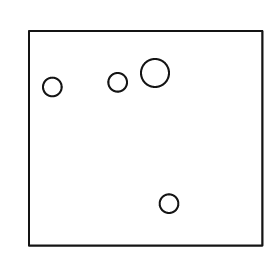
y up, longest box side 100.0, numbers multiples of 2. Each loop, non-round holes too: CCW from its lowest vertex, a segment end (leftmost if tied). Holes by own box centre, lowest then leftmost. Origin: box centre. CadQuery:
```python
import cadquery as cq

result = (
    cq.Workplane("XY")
    .moveTo(-50.0, -46.0)
    .lineTo(50.0, -46.0)
    .lineTo(50.0, 46.0)
    .lineTo(-50.0, 46.0)
    .close()
    .moveTo(10.0, -28.0)
    .circle(4.0)
    .moveTo(-40.0, 22.0)
    .circle(4.0)
    .moveTo(-12.0, 24.0)
    .circle(4.0)
    .moveTo(4.0, 28.0)
    .circle(6.0)
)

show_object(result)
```